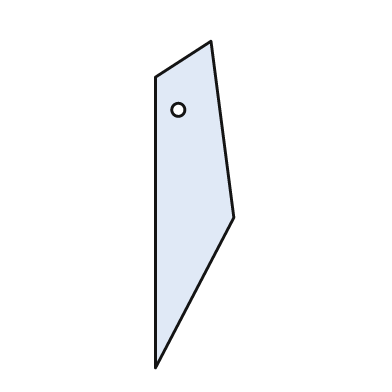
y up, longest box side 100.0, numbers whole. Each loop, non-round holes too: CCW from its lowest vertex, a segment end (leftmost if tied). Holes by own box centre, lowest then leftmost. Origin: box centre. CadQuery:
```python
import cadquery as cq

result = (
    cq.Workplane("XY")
    .moveTo(-12.0, -50.0)
    .lineTo(12.0, -4.0)
    .lineTo(5.0, 50.0)
    .lineTo(-12.0, 39.0)
    .close()
    .moveTo(-5.0, 29.0)
    .circle(2.0)
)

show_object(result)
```